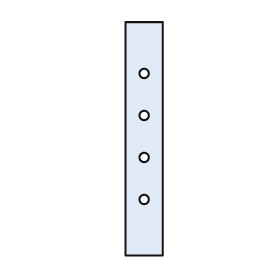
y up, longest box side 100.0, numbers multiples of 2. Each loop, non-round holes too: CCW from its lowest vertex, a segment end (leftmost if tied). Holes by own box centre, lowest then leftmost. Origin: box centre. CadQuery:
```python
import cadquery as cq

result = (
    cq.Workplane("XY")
    .moveTo(-8.0, -50.0)
    .lineTo(8.0, -50.0)
    .lineTo(8.0, 50.0)
    .lineTo(-8.0, 50.0)
    .close()
    .moveTo(0.0, -26.0)
    .circle(2.0)
    .moveTo(0.0, -8.0)
    .circle(2.0)
    .moveTo(0.0, 10.0)
    .circle(2.0)
    .moveTo(0.0, 28.0)
    .circle(2.0)
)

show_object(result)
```